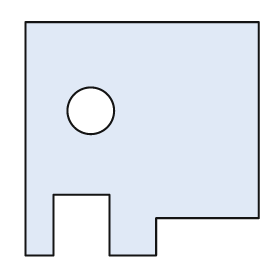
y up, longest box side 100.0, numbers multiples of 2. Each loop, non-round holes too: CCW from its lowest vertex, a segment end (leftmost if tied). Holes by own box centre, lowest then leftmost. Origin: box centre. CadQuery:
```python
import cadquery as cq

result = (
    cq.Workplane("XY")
    .moveTo(-50.0, -50.0)
    .lineTo(-38.0, -50.0)
    .lineTo(-38.0, -24.0)
    .lineTo(-14.0, -24.0)
    .lineTo(-14.0, -50.0)
    .lineTo(6.0, -50.0)
    .lineTo(6.0, -34.0)
    .lineTo(50.0, -34.0)
    .lineTo(50.0, 50.0)
    .lineTo(-50.0, 50.0)
    .close()
    .moveTo(-22.0, 12.0)
    .circle(10.0)
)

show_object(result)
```